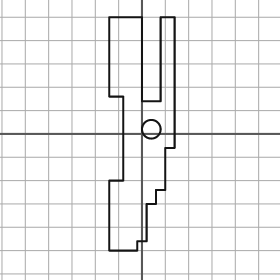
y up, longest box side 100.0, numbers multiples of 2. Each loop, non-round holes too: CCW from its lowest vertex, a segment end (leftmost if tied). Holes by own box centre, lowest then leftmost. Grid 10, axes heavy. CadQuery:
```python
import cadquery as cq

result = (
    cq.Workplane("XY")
    .moveTo(-14.0, -50.0)
    .lineTo(-2.0, -50.0)
    .lineTo(-2.0, -46.0)
    .lineTo(2.0, -46.0)
    .lineTo(2.0, -30.0)
    .lineTo(6.0, -30.0)
    .lineTo(6.0, -24.0)
    .lineTo(10.0, -24.0)
    .lineTo(10.0, -6.0)
    .lineTo(14.0, -6.0)
    .lineTo(14.0, 50.0)
    .lineTo(8.0, 50.0)
    .lineTo(8.0, 14.0)
    .lineTo(0.0, 14.0)
    .lineTo(0.0, 50.0)
    .lineTo(-14.0, 50.0)
    .lineTo(-14.0, 16.0)
    .lineTo(-8.0, 16.0)
    .lineTo(-8.0, -20.0)
    .lineTo(-14.0, -20.0)
    .close()
    .moveTo(4.0, 2.0)
    .circle(4.0)
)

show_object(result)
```